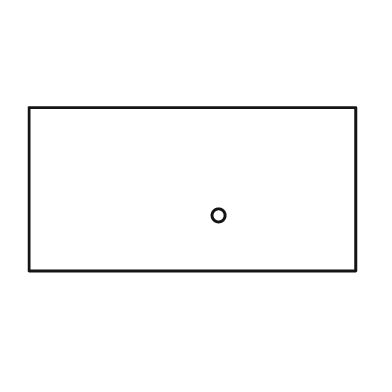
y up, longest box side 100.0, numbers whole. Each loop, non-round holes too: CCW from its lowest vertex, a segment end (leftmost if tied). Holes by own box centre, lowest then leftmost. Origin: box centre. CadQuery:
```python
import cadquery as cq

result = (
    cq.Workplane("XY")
    .moveTo(-50.0, -25.0)
    .lineTo(50.0, -25.0)
    .lineTo(50.0, 25.0)
    .lineTo(-50.0, 25.0)
    .close()
    .moveTo(8.0, -8.0)
    .circle(2.0)
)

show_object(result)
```